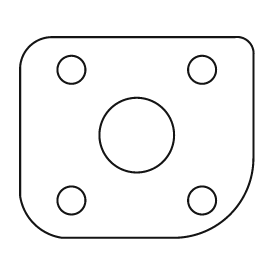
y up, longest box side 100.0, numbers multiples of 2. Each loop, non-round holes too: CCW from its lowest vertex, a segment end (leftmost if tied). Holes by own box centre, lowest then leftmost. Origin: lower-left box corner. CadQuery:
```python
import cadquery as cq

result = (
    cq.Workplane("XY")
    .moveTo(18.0, 0.0)
    .lineTo(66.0, 0.0)
    .threePointArc((90.0, 10.0), (100.0, 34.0))
    .lineTo(100.0, 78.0)
    .threePointArc((98.0, 84.0), (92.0, 86.0))
    .lineTo(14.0, 86.0)
    .threePointArc((4.0, 82.0), (0.0, 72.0))
    .lineTo(0.0, 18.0)
    .threePointArc((6.0, 6.0), (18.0, 0.0))
    .close()
    .moveTo(22.0, 16.0)
    .circle(6.0)
    .moveTo(78.0, 16.0)
    .circle(6.0)
    .moveTo(50.0, 44.0)
    .circle(16.0)
    .moveTo(22.0, 72.0)
    .circle(6.0)
    .moveTo(78.0, 72.0)
    .circle(6.0)
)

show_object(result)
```